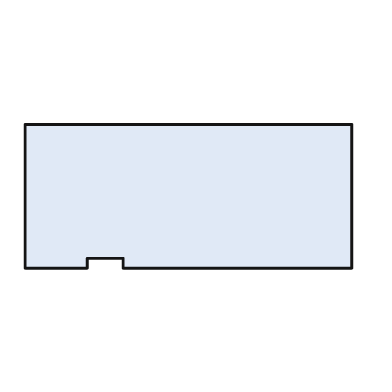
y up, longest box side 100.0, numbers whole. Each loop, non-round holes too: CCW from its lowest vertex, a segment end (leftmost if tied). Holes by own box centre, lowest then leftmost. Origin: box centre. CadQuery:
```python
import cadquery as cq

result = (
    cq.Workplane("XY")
    .moveTo(-50.0, -22.0)
    .lineTo(-31.0, -22.0)
    .lineTo(-31.0, -19.0)
    .lineTo(-20.0, -19.0)
    .lineTo(-20.0, -22.0)
    .lineTo(50.0, -22.0)
    .lineTo(50.0, 22.0)
    .lineTo(-50.0, 22.0)
    .close()
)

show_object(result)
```